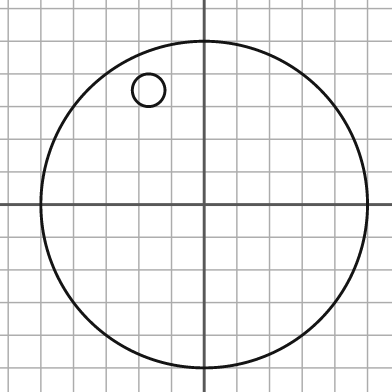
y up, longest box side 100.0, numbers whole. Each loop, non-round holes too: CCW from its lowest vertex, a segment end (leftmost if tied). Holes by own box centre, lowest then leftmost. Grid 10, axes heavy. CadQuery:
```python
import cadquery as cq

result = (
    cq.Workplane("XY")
    .moveTo(0.0, 0.0)
    .circle(50.0)
    .moveTo(-17.0, 35.0)
    .circle(5.0)
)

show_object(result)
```